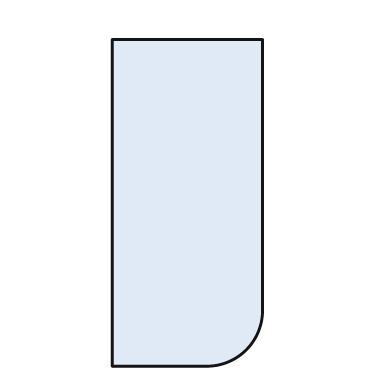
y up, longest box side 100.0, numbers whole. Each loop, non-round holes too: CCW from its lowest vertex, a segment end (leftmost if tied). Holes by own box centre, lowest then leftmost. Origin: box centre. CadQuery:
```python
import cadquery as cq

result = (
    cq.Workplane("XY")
    .moveTo(-23.0, -50.0)
    .lineTo(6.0, -50.0)
    .threePointArc((18.0, -45.0), (23.0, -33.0))
    .lineTo(23.0, 50.0)
    .lineTo(-23.0, 50.0)
    .close()
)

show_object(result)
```